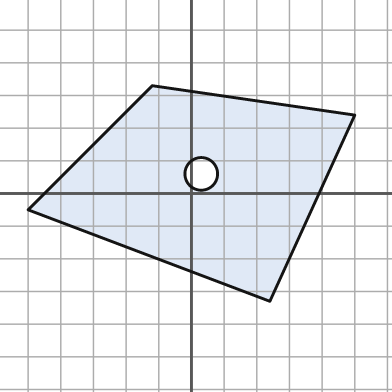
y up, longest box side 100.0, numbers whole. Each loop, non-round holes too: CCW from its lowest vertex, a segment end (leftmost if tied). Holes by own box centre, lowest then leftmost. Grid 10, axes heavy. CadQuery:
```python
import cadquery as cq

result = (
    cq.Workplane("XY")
    .moveTo(24.0, -33.0)
    .lineTo(50.0, 24.0)
    .lineTo(-12.0, 33.0)
    .lineTo(-50.0, -5.0)
    .close()
    .moveTo(3.0, 6.0)
    .circle(5.0)
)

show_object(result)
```